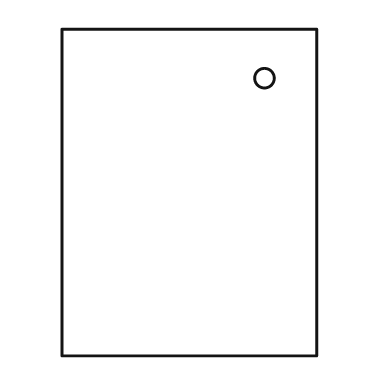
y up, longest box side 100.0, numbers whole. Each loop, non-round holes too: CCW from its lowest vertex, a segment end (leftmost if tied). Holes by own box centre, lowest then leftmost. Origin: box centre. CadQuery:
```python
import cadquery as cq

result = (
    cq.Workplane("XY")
    .moveTo(-39.0, -50.0)
    .lineTo(39.0, -50.0)
    .lineTo(39.0, 50.0)
    .lineTo(-39.0, 50.0)
    .close()
    .moveTo(23.0, 35.0)
    .circle(3.0)
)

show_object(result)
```